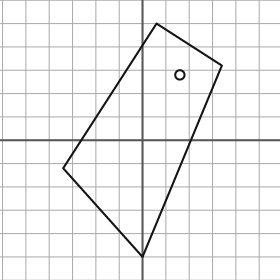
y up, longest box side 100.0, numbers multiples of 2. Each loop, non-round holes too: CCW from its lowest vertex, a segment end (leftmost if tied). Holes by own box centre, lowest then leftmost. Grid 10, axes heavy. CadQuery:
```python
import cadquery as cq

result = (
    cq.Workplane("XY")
    .moveTo(0.0, -50.0)
    .lineTo(34.0, 32.0)
    .lineTo(6.0, 50.0)
    .lineTo(-34.0, -12.0)
    .close()
    .moveTo(16.0, 28.0)
    .circle(2.0)
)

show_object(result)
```